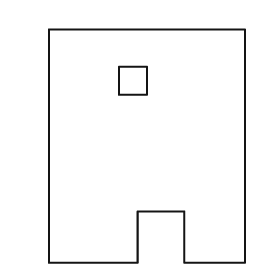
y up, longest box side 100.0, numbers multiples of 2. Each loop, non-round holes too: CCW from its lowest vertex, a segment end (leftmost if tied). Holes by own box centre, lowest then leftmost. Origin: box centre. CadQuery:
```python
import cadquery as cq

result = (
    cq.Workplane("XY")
    .moveTo(-42.0, -50.0)
    .lineTo(-4.0, -50.0)
    .lineTo(-4.0, -28.0)
    .lineTo(16.0, -28.0)
    .lineTo(16.0, -50.0)
    .lineTo(42.0, -50.0)
    .lineTo(42.0, 50.0)
    .lineTo(-42.0, 50.0)
    .close()
    .moveTo(-12.0, 22.0)
    .lineTo(0.0, 22.0)
    .lineTo(0.0, 34.0)
    .lineTo(-12.0, 34.0)
    .close()
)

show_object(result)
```